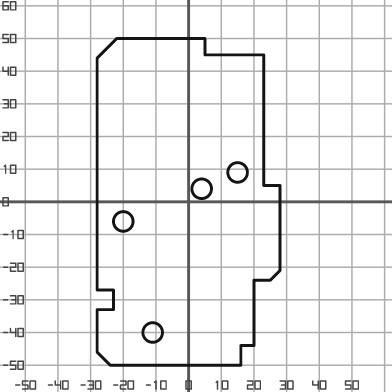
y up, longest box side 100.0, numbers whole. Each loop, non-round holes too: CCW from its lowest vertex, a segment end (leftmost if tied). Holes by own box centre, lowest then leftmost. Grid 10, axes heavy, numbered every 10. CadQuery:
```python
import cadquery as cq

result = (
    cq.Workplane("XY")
    .moveTo(-24.0, -50.0)
    .lineTo(16.0, -50.0)
    .lineTo(16.0, -44.0)
    .lineTo(20.0, -44.0)
    .lineTo(20.0, -24.0)
    .lineTo(25.0, -24.0)
    .lineTo(28.0, -21.0)
    .lineTo(28.0, 5.0)
    .lineTo(23.0, 5.0)
    .lineTo(23.0, 45.0)
    .lineTo(5.0, 45.0)
    .lineTo(5.0, 50.0)
    .lineTo(-22.0, 50.0)
    .lineTo(-28.0, 44.0)
    .lineTo(-28.0, -27.0)
    .lineTo(-23.0, -27.0)
    .lineTo(-23.0, -33.0)
    .lineTo(-28.0, -33.0)
    .lineTo(-28.0, -46.0)
    .close()
    .moveTo(-11.0, -40.0)
    .circle(3.0)
    .moveTo(-20.0, -6.0)
    .circle(3.0)
    .moveTo(4.0, 4.0)
    .circle(3.0)
    .moveTo(15.0, 9.0)
    .circle(3.0)
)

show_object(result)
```